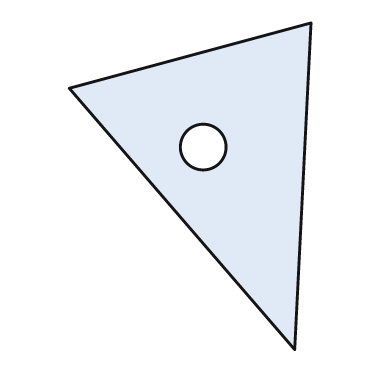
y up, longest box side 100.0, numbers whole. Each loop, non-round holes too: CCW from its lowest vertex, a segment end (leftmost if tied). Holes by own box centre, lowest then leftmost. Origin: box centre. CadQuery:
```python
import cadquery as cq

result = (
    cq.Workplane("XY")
    .moveTo(32.0, -50.0)
    .lineTo(37.0, 50.0)
    .lineTo(-37.0, 30.0)
    .close()
    .moveTo(4.0, 12.0)
    .circle(7.0)
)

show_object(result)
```